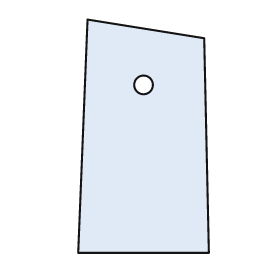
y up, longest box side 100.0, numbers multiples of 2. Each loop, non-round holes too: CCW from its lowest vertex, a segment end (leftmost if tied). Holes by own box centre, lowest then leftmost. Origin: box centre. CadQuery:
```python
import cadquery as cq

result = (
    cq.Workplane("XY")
    .moveTo(-28.0, -50.0)
    .lineTo(28.0, -50.0)
    .lineTo(26.0, 42.0)
    .lineTo(-24.0, 50.0)
    .close()
    .moveTo(0.0, 22.0)
    .circle(4.0)
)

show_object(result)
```